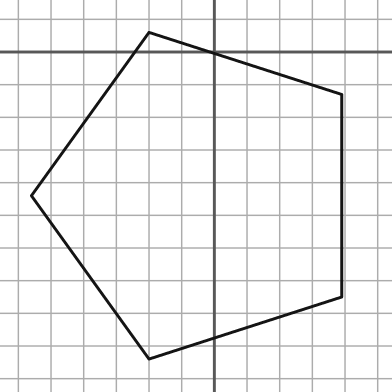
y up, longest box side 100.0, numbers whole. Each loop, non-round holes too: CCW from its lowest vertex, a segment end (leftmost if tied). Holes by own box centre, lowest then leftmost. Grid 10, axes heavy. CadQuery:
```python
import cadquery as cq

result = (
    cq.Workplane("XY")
    .moveTo(-20.0, -94.0)
    .lineTo(39.0, -75.0)
    .lineTo(39.0, -13.0)
    .lineTo(-20.0, 6.0)
    .lineTo(-56.0, -44.0)
    .close()
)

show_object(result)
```